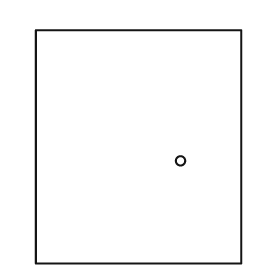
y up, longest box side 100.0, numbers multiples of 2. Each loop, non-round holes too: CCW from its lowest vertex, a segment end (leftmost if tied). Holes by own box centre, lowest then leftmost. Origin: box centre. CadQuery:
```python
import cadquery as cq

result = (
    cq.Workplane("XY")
    .moveTo(-44.0, -50.0)
    .lineTo(44.0, -50.0)
    .lineTo(44.0, 50.0)
    .lineTo(-44.0, 50.0)
    .close()
    .moveTo(18.0, -6.0)
    .circle(2.0)
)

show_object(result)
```